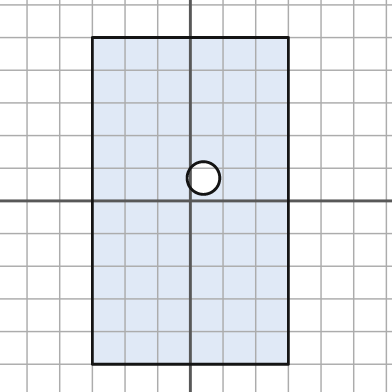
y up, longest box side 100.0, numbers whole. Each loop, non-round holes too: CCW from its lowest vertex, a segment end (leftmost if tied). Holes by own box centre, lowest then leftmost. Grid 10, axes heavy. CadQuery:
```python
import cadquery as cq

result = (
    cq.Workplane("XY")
    .moveTo(-30.0, -50.0)
    .lineTo(30.0, -50.0)
    .lineTo(30.0, 50.0)
    .lineTo(-30.0, 50.0)
    .close()
    .moveTo(4.0, 7.0)
    .circle(5.0)
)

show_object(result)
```